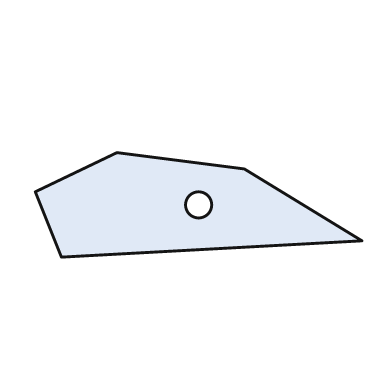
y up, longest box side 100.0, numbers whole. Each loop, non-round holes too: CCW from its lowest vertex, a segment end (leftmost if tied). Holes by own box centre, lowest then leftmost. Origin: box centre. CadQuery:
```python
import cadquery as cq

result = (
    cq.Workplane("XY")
    .moveTo(-42.0, -16.0)
    .lineTo(50.0, -11.0)
    .lineTo(14.0, 11.0)
    .lineTo(-25.0, 16.0)
    .lineTo(-50.0, 4.0)
    .close()
    .moveTo(0.0, 0.0)
    .circle(4.0)
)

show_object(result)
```